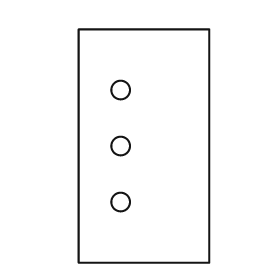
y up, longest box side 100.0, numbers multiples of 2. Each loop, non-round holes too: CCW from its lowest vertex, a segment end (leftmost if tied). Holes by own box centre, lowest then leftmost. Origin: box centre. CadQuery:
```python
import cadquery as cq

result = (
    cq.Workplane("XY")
    .moveTo(-28.0, -50.0)
    .lineTo(28.0, -50.0)
    .lineTo(28.0, 50.0)
    .lineTo(-28.0, 50.0)
    .close()
    .moveTo(-10.0, -24.0)
    .circle(4.0)
    .moveTo(-10.0, 0.0)
    .circle(4.0)
    .moveTo(-10.0, 24.0)
    .circle(4.0)
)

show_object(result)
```